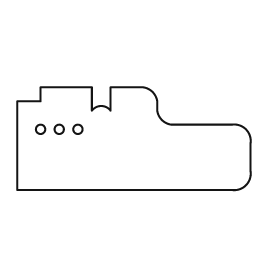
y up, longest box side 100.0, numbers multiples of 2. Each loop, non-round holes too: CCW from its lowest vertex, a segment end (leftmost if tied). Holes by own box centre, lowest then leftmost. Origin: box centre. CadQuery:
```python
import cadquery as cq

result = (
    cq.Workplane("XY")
    .moveTo(-50.0, -22.0)
    .lineTo(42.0, -22.0)
    .threePointArc((48.0, -20.0), (50.0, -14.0))
    .lineTo(50.0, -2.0)
    .threePointArc((48.0, 4.0), (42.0, 6.0))
    .lineTo(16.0, 6.0)
    .threePointArc((12.0, 8.0), (10.0, 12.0))
    .lineTo(10.0, 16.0)
    .threePointArc((8.0, 20.0), (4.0, 22.0))
    .lineTo(-10.0, 22.0)
    .lineTo(-10.0, 12.0)
    .threePointArc((-14.0, 14.0), (-18.0, 12.0))
    .lineTo(-18.0, 22.0)
    .lineTo(-40.0, 22.0)
    .lineTo(-40.0, 16.0)
    .lineTo(-50.0, 16.0)
    .close()
    .moveTo(-40.0, 4.0)
    .circle(2.0)
    .moveTo(-32.0, 4.0)
    .circle(2.0)
    .moveTo(-24.0, 4.0)
    .circle(2.0)
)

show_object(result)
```